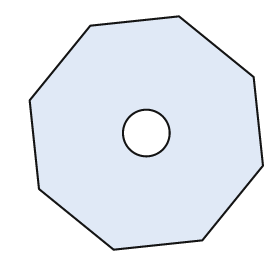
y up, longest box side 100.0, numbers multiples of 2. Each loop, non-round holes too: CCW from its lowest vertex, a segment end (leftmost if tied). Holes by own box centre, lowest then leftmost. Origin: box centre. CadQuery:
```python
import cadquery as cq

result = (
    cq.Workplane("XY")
    .moveTo(-14.0, -50.0)
    .lineTo(24.0, -46.0)
    .lineTo(50.0, -14.0)
    .lineTo(46.0, 24.0)
    .lineTo(14.0, 50.0)
    .lineTo(-24.0, 46.0)
    .lineTo(-50.0, 14.0)
    .lineTo(-46.0, -24.0)
    .close()
    .moveTo(0.0, 0.0)
    .circle(10.0)
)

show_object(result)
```